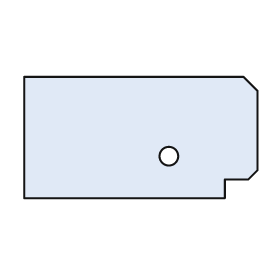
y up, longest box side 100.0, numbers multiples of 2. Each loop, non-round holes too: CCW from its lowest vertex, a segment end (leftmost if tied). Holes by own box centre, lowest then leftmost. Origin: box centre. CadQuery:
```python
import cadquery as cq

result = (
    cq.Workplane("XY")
    .moveTo(-50.0, -26.0)
    .lineTo(36.0, -26.0)
    .lineTo(36.0, -18.0)
    .lineTo(46.0, -18.0)
    .lineTo(50.0, -14.0)
    .lineTo(50.0, 20.0)
    .lineTo(44.0, 26.0)
    .lineTo(-50.0, 26.0)
    .close()
    .moveTo(12.0, -8.0)
    .circle(4.0)
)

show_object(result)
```